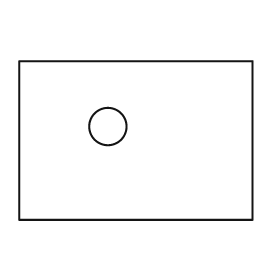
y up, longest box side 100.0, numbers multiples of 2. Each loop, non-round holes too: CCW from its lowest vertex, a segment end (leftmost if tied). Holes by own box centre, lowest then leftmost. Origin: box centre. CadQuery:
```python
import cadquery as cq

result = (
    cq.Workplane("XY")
    .moveTo(-50.0, -34.0)
    .lineTo(50.0, -34.0)
    .lineTo(50.0, 34.0)
    .lineTo(-50.0, 34.0)
    .close()
    .moveTo(-12.0, 6.0)
    .circle(8.0)
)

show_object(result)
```